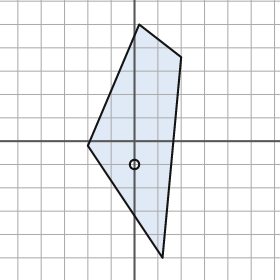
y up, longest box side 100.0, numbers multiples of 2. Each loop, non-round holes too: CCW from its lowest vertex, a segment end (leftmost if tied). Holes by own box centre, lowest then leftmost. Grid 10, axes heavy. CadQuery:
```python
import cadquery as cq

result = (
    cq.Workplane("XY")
    .moveTo(12.0, -50.0)
    .lineTo(20.0, 36.0)
    .lineTo(2.0, 50.0)
    .lineTo(-20.0, -2.0)
    .close()
    .moveTo(0.0, -10.0)
    .circle(2.0)
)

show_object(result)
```